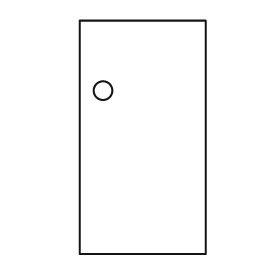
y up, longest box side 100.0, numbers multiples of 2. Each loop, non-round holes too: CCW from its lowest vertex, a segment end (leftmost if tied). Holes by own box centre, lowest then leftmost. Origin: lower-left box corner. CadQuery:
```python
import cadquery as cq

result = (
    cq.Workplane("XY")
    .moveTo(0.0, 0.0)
    .lineTo(54.0, 0.0)
    .lineTo(54.0, 100.0)
    .lineTo(0.0, 100.0)
    .close()
    .moveTo(10.0, 70.0)
    .circle(4.0)
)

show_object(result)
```